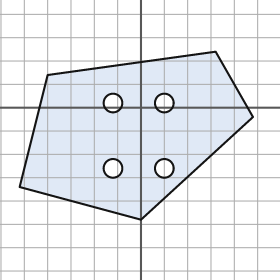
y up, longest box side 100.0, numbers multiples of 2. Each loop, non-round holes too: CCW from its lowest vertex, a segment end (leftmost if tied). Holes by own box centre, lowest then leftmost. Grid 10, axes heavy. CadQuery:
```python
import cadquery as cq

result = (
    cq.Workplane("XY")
    .moveTo(0.0, -48.0)
    .lineTo(48.0, -4.0)
    .lineTo(32.0, 24.0)
    .lineTo(-40.0, 14.0)
    .lineTo(-52.0, -34.0)
    .close()
    .moveTo(-12.0, -26.0)
    .circle(4.0)
    .moveTo(10.0, -26.0)
    .circle(4.0)
    .moveTo(-12.0, 2.0)
    .circle(4.0)
    .moveTo(10.0, 2.0)
    .circle(4.0)
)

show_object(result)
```